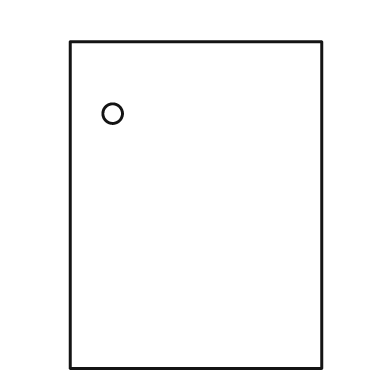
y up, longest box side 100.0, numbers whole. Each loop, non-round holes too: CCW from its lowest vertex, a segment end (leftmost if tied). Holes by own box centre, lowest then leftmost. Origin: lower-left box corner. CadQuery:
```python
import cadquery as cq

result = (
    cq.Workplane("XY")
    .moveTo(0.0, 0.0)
    .lineTo(77.0, 0.0)
    .lineTo(77.0, 100.0)
    .lineTo(0.0, 100.0)
    .close()
    .moveTo(13.0, 78.0)
    .circle(3.0)
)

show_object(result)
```